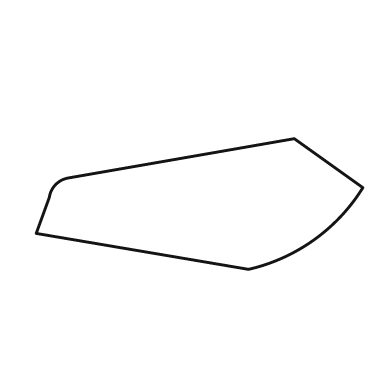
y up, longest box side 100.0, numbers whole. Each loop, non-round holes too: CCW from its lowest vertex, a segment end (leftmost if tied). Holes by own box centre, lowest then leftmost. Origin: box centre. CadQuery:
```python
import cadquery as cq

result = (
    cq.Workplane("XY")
    .moveTo(15.0, -20.0)
    .threePointArc((35.0, -11.0), (50.0, 5.0))
    .lineTo(29.0, 20.0)
    .lineTo(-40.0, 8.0)
    .threePointArc((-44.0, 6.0), (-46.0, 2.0))
    .lineTo(-50.0, -9.0)
    .close()
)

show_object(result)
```